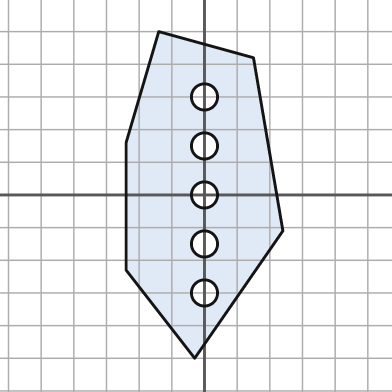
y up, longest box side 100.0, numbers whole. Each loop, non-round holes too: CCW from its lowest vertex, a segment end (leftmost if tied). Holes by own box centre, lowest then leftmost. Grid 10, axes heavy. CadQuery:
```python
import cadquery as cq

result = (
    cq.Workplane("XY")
    .moveTo(-3.0, -50.0)
    .lineTo(24.0, -11.0)
    .lineTo(15.0, 42.0)
    .lineTo(-14.0, 50.0)
    .lineTo(-24.0, 16.0)
    .lineTo(-24.0, -23.0)
    .close()
    .moveTo(0.0, -30.0)
    .circle(4.0)
    .moveTo(0.0, -15.0)
    .circle(4.0)
    .moveTo(0.0, 0.0)
    .circle(4.0)
    .moveTo(0.0, 15.0)
    .circle(4.0)
    .moveTo(0.0, 30.0)
    .circle(4.0)
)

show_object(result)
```